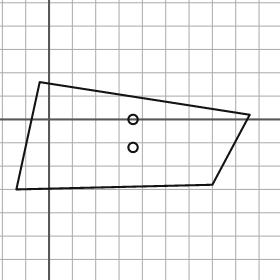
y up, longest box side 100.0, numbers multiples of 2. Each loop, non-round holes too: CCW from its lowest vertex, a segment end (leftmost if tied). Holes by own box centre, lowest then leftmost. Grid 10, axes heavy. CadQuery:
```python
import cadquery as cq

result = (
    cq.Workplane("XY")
    .moveTo(-14.0, -30.0)
    .lineTo(70.0, -28.0)
    .lineTo(86.0, 2.0)
    .lineTo(-4.0, 16.0)
    .close()
    .moveTo(36.0, -12.0)
    .circle(2.0)
    .moveTo(36.0, 0.0)
    .circle(2.0)
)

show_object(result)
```